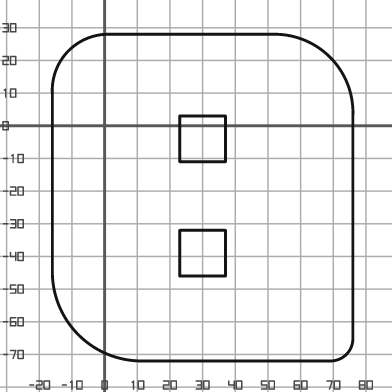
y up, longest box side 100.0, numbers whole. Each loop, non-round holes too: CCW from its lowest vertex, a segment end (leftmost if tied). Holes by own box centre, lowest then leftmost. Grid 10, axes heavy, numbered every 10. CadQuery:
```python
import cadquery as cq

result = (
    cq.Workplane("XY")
    .moveTo(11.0, -72.0)
    .lineTo(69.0, -72.0)
    .threePointArc((74.0, -70.0), (76.0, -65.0))
    .lineTo(76.0, 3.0)
    .threePointArc((69.0, 21.0), (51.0, 28.0))
    .lineTo(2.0, 28.0)
    .threePointArc((-11.0, 23.0), (-16.0, 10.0))
    .lineTo(-16.0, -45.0)
    .threePointArc((-8.0, -64.0), (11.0, -72.0))
    .close()
    .moveTo(23.0, -46.0)
    .lineTo(37.0, -46.0)
    .lineTo(37.0, -32.0)
    .lineTo(23.0, -32.0)
    .close()
    .moveTo(23.0, -11.0)
    .lineTo(37.0, -11.0)
    .lineTo(37.0, 3.0)
    .lineTo(23.0, 3.0)
    .close()
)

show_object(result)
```